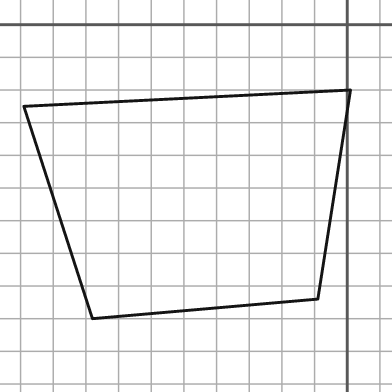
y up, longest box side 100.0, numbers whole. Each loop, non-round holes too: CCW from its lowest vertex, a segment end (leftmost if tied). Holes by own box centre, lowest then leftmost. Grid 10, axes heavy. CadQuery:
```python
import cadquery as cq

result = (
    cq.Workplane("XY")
    .moveTo(-78.0, -90.0)
    .lineTo(-9.0, -84.0)
    .lineTo(1.0, -20.0)
    .lineTo(-99.0, -25.0)
    .close()
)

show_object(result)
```